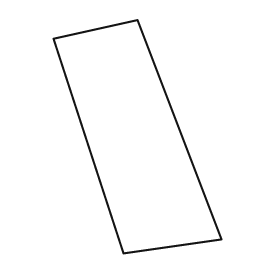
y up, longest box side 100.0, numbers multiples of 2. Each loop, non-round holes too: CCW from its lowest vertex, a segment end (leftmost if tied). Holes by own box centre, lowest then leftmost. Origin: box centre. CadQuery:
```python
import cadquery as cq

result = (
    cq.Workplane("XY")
    .moveTo(-6.0, -50.0)
    .lineTo(36.0, -44.0)
    .lineTo(0.0, 50.0)
    .lineTo(-36.0, 42.0)
    .close()
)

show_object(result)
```